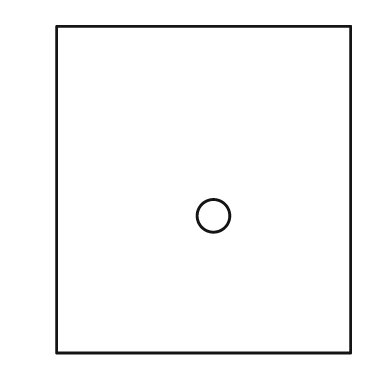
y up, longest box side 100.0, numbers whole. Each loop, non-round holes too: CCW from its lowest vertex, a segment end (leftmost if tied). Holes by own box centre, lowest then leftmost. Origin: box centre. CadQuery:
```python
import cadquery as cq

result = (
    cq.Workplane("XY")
    .moveTo(-45.0, -50.0)
    .lineTo(45.0, -50.0)
    .lineTo(45.0, 50.0)
    .lineTo(-45.0, 50.0)
    .close()
    .moveTo(3.0, -8.0)
    .circle(5.0)
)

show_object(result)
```